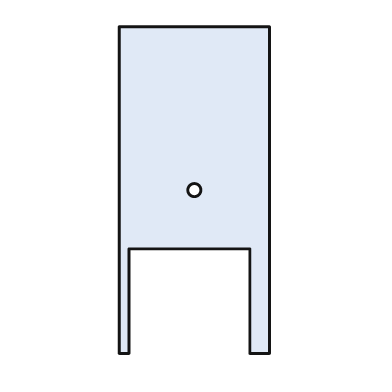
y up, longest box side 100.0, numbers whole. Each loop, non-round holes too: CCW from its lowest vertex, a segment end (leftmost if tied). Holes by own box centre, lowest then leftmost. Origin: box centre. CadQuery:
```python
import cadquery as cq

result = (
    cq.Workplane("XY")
    .moveTo(-23.0, -50.0)
    .lineTo(-20.0, -50.0)
    .lineTo(-20.0, -18.0)
    .lineTo(17.0, -18.0)
    .lineTo(17.0, -50.0)
    .lineTo(23.0, -50.0)
    .lineTo(23.0, 50.0)
    .lineTo(-23.0, 50.0)
    .close()
    .moveTo(0.0, 0.0)
    .circle(2.0)
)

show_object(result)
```